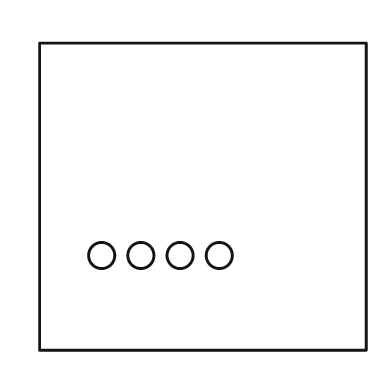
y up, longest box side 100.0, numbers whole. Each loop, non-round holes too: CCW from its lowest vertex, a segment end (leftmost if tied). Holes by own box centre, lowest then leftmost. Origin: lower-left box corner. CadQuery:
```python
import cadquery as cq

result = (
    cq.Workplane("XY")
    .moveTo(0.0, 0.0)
    .lineTo(100.0, 0.0)
    .lineTo(100.0, 94.0)
    .lineTo(0.0, 94.0)
    .close()
    .moveTo(19.0, 29.0)
    .circle(4.0)
    .moveTo(31.0, 29.0)
    .circle(4.0)
    .moveTo(43.0, 29.0)
    .circle(4.0)
    .moveTo(55.0, 29.0)
    .circle(4.0)
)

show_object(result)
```